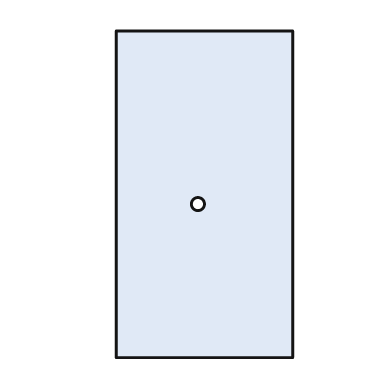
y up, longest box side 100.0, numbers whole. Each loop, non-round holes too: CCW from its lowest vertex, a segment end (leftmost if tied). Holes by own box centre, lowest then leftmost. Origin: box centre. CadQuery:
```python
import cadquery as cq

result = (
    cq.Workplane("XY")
    .moveTo(-27.0, -50.0)
    .lineTo(27.0, -50.0)
    .lineTo(27.0, 50.0)
    .lineTo(-27.0, 50.0)
    .close()
    .moveTo(-2.0, -3.0)
    .circle(2.0)
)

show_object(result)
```